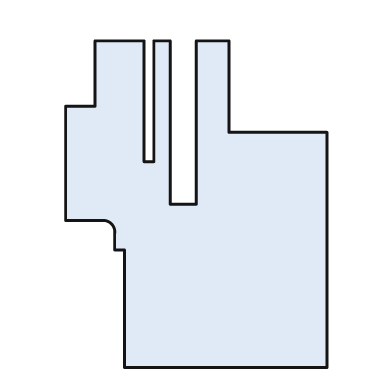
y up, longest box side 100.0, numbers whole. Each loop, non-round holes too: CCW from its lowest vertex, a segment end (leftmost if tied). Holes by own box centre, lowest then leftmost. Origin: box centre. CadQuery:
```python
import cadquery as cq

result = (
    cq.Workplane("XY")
    .moveTo(-22.0, -50.0)
    .lineTo(40.0, -50.0)
    .lineTo(40.0, 22.0)
    .lineTo(10.0, 22.0)
    .lineTo(10.0, 50.0)
    .lineTo(0.0, 50.0)
    .lineTo(0.0, 0.0)
    .lineTo(-8.0, 0.0)
    .lineTo(-8.0, 50.0)
    .lineTo(-13.0, 50.0)
    .lineTo(-13.0, 13.0)
    .lineTo(-16.0, 13.0)
    .lineTo(-16.0, 50.0)
    .lineTo(-31.0, 50.0)
    .lineTo(-31.0, 30.0)
    .lineTo(-40.0, 30.0)
    .lineTo(-40.0, -5.0)
    .lineTo(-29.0, -5.0)
    .threePointArc((-26.0, -6.0), (-25.0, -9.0))
    .lineTo(-25.0, -14.0)
    .lineTo(-22.0, -14.0)
    .close()
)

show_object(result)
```